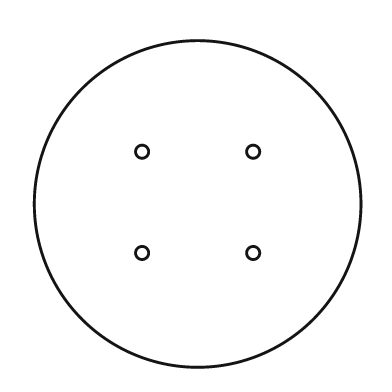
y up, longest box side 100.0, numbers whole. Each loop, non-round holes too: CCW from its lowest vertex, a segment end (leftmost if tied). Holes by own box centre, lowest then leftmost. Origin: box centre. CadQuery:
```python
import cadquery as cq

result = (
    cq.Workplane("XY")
    .moveTo(0.0, 0.0)
    .circle(50.0)
    .moveTo(-17.0, -15.0)
    .circle(2.0)
    .moveTo(17.0, -15.0)
    .circle(2.0)
    .moveTo(-17.0, 16.0)
    .circle(2.0)
    .moveTo(17.0, 16.0)
    .circle(2.0)
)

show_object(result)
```